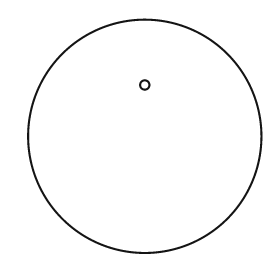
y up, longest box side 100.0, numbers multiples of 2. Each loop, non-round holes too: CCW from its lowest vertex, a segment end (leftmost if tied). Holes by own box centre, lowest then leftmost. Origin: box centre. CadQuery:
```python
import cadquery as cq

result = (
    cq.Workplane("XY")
    .moveTo(0.0, 0.0)
    .circle(50.0)
    .moveTo(0.0, 22.0)
    .circle(2.0)
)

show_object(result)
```